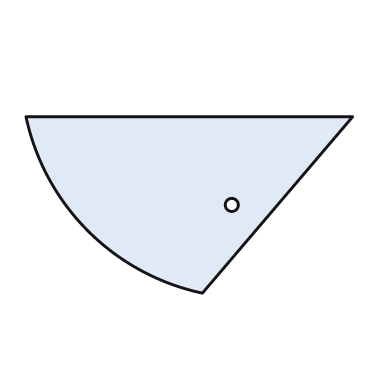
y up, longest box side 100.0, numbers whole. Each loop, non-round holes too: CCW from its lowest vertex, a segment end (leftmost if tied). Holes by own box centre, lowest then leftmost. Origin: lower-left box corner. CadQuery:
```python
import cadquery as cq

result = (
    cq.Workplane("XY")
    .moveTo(54.0, 0.0)
    .lineTo(100.0, 54.0)
    .lineTo(0.0, 54.0)
    .threePointArc((19.0, 19.0), (54.0, 0.0))
    .close()
    .moveTo(63.0, 27.0)
    .circle(2.0)
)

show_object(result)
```